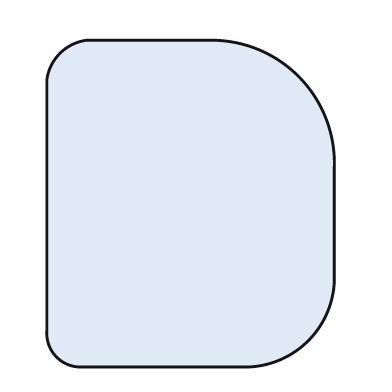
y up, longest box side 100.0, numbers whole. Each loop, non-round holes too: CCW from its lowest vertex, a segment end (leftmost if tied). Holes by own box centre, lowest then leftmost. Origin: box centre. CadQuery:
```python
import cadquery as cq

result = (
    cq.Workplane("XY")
    .moveTo(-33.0, -50.0)
    .lineTo(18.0, -50.0)
    .threePointArc((36.0, -42.0), (44.0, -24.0))
    .lineTo(44.0, 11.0)
    .threePointArc((33.0, 39.0), (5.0, 50.0))
    .lineTo(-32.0, 50.0)
    .threePointArc((-40.0, 46.0), (-44.0, 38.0))
    .lineTo(-44.0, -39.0)
    .threePointArc((-41.0, -47.0), (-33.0, -50.0))
    .close()
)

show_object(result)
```